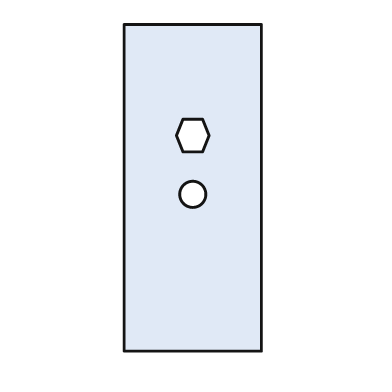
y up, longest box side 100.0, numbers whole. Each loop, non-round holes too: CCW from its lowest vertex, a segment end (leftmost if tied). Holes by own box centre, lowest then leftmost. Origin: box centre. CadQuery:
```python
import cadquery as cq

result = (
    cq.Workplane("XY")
    .moveTo(-21.0, -50.0)
    .lineTo(21.0, -50.0)
    .lineTo(21.0, 50.0)
    .lineTo(-21.0, 50.0)
    .close()
    .moveTo(0.0, -2.0)
    .circle(4.0)
    .moveTo(-3.0, 11.0)
    .lineTo(3.0, 11.0)
    .lineTo(5.0, 16.0)
    .lineTo(3.0, 21.0)
    .lineTo(-3.0, 21.0)
    .lineTo(-5.0, 16.0)
    .close()
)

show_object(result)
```